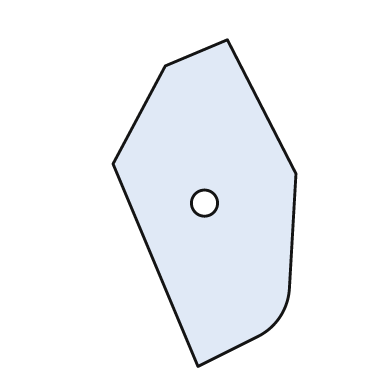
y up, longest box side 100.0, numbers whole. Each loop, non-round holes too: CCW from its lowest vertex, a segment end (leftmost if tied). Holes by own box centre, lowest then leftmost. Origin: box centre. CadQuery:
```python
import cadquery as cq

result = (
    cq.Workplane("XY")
    .moveTo(-2.0, -50.0)
    .lineTo(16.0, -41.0)
    .threePointArc((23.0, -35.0), (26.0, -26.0))
    .lineTo(28.0, 9.0)
    .lineTo(7.0, 50.0)
    .lineTo(-12.0, 42.0)
    .lineTo(-28.0, 12.0)
    .close()
    .moveTo(0.0, 0.0)
    .circle(4.0)
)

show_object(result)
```